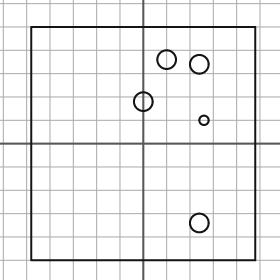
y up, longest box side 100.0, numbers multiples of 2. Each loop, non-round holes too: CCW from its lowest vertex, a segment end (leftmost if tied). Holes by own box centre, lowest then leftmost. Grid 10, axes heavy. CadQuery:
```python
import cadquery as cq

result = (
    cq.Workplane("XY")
    .moveTo(-48.0, -50.0)
    .lineTo(48.0, -50.0)
    .lineTo(48.0, 50.0)
    .lineTo(-48.0, 50.0)
    .close()
    .moveTo(24.0, -34.0)
    .circle(4.0)
    .moveTo(26.0, 10.0)
    .circle(2.0)
    .moveTo(0.0, 18.0)
    .circle(4.0)
    .moveTo(24.0, 34.0)
    .circle(4.0)
    .moveTo(10.0, 36.0)
    .circle(4.0)
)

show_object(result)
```